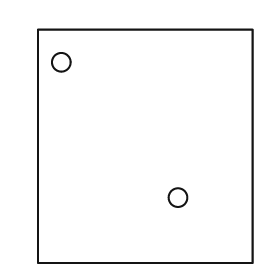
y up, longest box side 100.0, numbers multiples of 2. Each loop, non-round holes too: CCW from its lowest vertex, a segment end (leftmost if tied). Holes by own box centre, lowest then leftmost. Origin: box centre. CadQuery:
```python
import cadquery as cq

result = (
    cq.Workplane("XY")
    .moveTo(-46.0, -50.0)
    .lineTo(46.0, -50.0)
    .lineTo(46.0, 50.0)
    .lineTo(-46.0, 50.0)
    .close()
    .moveTo(14.0, -22.0)
    .circle(4.0)
    .moveTo(-36.0, 36.0)
    .circle(4.0)
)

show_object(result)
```